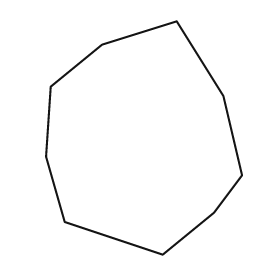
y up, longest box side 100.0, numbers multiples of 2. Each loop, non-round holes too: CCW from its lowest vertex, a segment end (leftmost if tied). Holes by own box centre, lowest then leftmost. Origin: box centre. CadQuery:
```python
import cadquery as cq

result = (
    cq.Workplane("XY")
    .moveTo(8.0, -50.0)
    .lineTo(30.0, -32.0)
    .lineTo(42.0, -16.0)
    .lineTo(34.0, 18.0)
    .lineTo(14.0, 50.0)
    .lineTo(-18.0, 40.0)
    .lineTo(-40.0, 22.0)
    .lineTo(-42.0, -8.0)
    .lineTo(-34.0, -36.0)
    .close()
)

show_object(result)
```